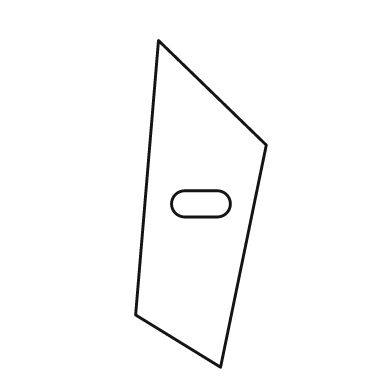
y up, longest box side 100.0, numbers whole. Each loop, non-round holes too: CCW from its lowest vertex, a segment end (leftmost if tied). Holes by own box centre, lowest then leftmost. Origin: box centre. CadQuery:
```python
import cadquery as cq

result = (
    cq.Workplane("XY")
    .moveTo(6.0, -50.0)
    .lineTo(20.0, 18.0)
    .lineTo(-13.0, 50.0)
    .lineTo(-20.0, -34.0)
    .close()
    .moveTo(-5.0, -4.0)
    .lineTo(5.0, -4.0)
    .threePointArc((9.0, 0.0), (5.0, 4.0))
    .lineTo(-5.0, 4.0)
    .threePointArc((-9.0, 0.0), (-5.0, -4.0))
    .close()
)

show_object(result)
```